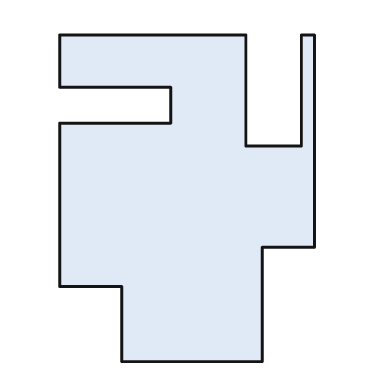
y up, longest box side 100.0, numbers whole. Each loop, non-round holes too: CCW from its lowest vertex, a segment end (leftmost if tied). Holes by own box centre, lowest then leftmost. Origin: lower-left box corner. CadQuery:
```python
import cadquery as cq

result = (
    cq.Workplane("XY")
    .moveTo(19.0, 0.0)
    .lineTo(62.0, 0.0)
    .lineTo(62.0, 35.0)
    .lineTo(78.0, 35.0)
    .lineTo(78.0, 100.0)
    .lineTo(74.0, 100.0)
    .lineTo(74.0, 66.0)
    .lineTo(57.0, 66.0)
    .lineTo(57.0, 100.0)
    .lineTo(0.0, 100.0)
    .lineTo(0.0, 84.0)
    .lineTo(34.0, 84.0)
    .lineTo(34.0, 73.0)
    .lineTo(0.0, 73.0)
    .lineTo(0.0, 23.0)
    .lineTo(19.0, 23.0)
    .close()
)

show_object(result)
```